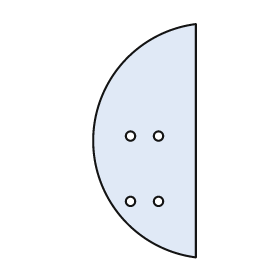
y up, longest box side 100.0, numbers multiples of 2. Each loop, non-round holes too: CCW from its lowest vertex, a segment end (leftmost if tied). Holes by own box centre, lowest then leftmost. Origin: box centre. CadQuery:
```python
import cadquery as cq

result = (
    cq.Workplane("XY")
    .moveTo(22.0, -50.0)
    .lineTo(22.0, 50.0)
    .threePointArc((-22.0, 0.0), (22.0, -50.0))
    .close()
    .moveTo(-6.0, -26.0)
    .circle(2.0)
    .moveTo(6.0, -26.0)
    .circle(2.0)
    .moveTo(-6.0, 2.0)
    .circle(2.0)
    .moveTo(6.0, 2.0)
    .circle(2.0)
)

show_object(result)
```